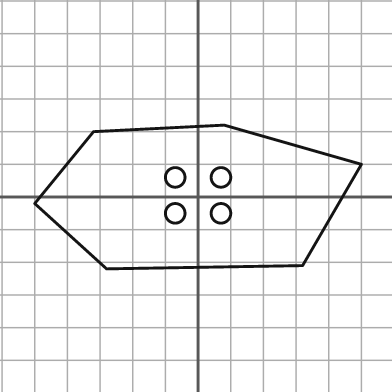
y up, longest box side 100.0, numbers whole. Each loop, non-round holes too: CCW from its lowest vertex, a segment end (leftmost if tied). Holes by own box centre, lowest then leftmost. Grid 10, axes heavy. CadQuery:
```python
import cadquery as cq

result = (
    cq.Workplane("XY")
    .moveTo(-28.0, -22.0)
    .lineTo(32.0, -21.0)
    .lineTo(50.0, 10.0)
    .lineTo(8.0, 22.0)
    .lineTo(-32.0, 20.0)
    .lineTo(-50.0, -2.0)
    .close()
    .moveTo(-7.0, -5.0)
    .circle(3.0)
    .moveTo(7.0, -5.0)
    .circle(3.0)
    .moveTo(-7.0, 6.0)
    .circle(3.0)
    .moveTo(7.0, 6.0)
    .circle(3.0)
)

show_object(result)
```